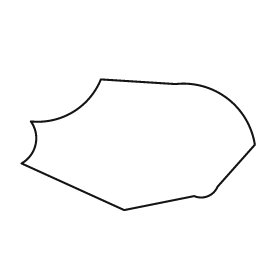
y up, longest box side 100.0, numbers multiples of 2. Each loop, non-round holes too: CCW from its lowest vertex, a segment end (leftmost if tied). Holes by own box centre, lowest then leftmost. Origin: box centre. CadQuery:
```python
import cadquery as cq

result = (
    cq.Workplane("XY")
    .moveTo(-6.0, -28.0)
    .lineTo(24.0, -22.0)
    .threePointArc((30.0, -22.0), (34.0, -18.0))
    .lineTo(50.0, 0.0)
    .threePointArc((38.0, 20.0), (16.0, 26.0))
    .lineTo(-16.0, 28.0)
    .threePointArc((-28.0, 14.0), (-46.0, 10.0))
    .threePointArc((-44.0, 0.0), (-50.0, -8.0))
    .close()
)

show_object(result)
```